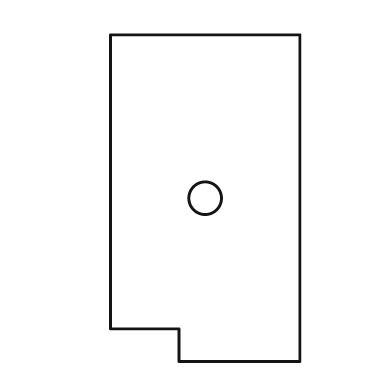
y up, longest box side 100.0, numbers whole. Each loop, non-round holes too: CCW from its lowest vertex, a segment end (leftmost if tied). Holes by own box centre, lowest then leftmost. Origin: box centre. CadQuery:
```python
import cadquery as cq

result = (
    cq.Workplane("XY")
    .moveTo(-8.0, -50.0)
    .lineTo(29.0, -50.0)
    .lineTo(29.0, 50.0)
    .lineTo(-29.0, 50.0)
    .lineTo(-29.0, -40.0)
    .lineTo(-8.0, -40.0)
    .close()
    .moveTo(0.0, 0.0)
    .circle(5.0)
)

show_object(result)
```